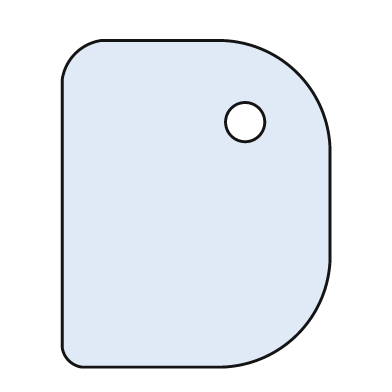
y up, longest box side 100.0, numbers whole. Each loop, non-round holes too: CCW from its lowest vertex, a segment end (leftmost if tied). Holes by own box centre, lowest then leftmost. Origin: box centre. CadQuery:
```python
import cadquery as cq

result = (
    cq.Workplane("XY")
    .moveTo(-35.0, -50.0)
    .lineTo(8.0, -50.0)
    .threePointArc((31.0, -40.0), (41.0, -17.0))
    .lineTo(41.0, 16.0)
    .threePointArc((31.0, 40.0), (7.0, 50.0))
    .lineTo(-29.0, 50.0)
    .threePointArc((-37.0, 46.0), (-41.0, 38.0))
    .lineTo(-41.0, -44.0)
    .threePointArc((-39.0, -48.0), (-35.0, -50.0))
    .close()
    .moveTo(15.0, 25.0)
    .circle(6.0)
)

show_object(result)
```